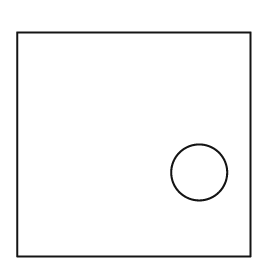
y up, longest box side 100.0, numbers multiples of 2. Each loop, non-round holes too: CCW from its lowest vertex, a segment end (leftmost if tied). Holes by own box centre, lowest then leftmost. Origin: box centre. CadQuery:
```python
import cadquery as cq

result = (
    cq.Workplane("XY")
    .moveTo(-50.0, -48.0)
    .lineTo(50.0, -48.0)
    .lineTo(50.0, 48.0)
    .lineTo(-50.0, 48.0)
    .close()
    .moveTo(28.0, -12.0)
    .circle(12.0)
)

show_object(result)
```